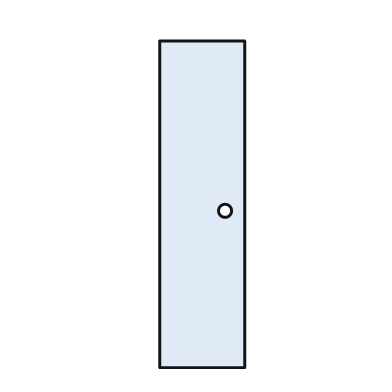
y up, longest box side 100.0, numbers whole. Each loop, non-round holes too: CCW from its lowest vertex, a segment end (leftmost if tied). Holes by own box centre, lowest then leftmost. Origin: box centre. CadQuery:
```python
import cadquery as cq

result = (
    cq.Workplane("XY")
    .moveTo(-13.0, -50.0)
    .lineTo(13.0, -50.0)
    .lineTo(13.0, 50.0)
    .lineTo(-13.0, 50.0)
    .close()
    .moveTo(7.0, -2.0)
    .circle(2.0)
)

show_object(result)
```